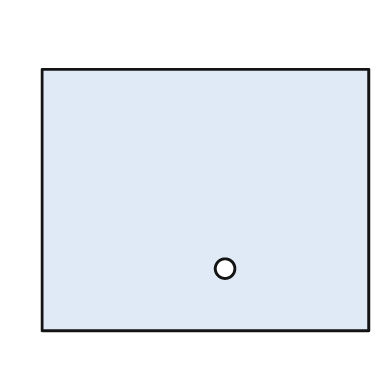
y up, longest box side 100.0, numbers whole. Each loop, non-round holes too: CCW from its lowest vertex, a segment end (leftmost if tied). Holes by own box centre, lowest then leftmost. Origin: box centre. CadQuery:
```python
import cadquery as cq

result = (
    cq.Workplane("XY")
    .moveTo(-50.0, -40.0)
    .lineTo(50.0, -40.0)
    .lineTo(50.0, 40.0)
    .lineTo(-50.0, 40.0)
    .close()
    .moveTo(6.0, -21.0)
    .circle(3.0)
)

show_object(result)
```